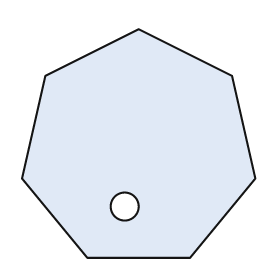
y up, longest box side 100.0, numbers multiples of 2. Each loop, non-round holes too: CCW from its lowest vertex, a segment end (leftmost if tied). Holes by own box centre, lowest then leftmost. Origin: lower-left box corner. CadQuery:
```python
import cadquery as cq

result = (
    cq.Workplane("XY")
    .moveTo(28.0, 0.0)
    .lineTo(72.0, 0.0)
    .lineTo(100.0, 34.0)
    .lineTo(90.0, 78.0)
    .lineTo(50.0, 98.0)
    .lineTo(10.0, 78.0)
    .lineTo(0.0, 34.0)
    .close()
    .moveTo(44.0, 22.0)
    .circle(6.0)
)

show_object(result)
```